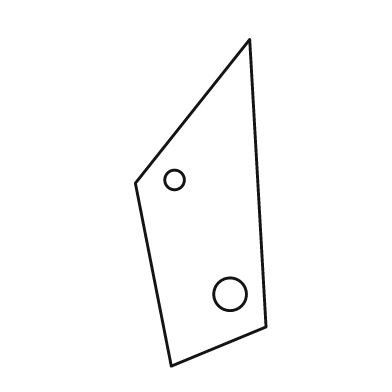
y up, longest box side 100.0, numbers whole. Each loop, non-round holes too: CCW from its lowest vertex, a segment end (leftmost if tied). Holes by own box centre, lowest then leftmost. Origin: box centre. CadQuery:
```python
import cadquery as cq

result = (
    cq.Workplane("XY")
    .moveTo(-9.0, -50.0)
    .lineTo(20.0, -38.0)
    .lineTo(15.0, 50.0)
    .lineTo(-20.0, 6.0)
    .close()
    .moveTo(9.0, -28.0)
    .circle(5.0)
    .moveTo(-8.0, 7.0)
    .circle(3.0)
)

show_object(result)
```